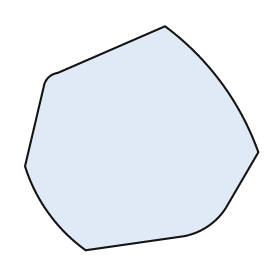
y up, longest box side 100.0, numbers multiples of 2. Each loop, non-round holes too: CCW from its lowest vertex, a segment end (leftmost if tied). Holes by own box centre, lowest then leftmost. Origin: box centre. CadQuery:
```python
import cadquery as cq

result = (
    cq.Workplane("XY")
    .moveTo(-24.0, -48.0)
    .lineTo(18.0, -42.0)
    .threePointArc((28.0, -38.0), (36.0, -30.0))
    .lineTo(50.0, -6.0)
    .threePointArc((34.0, 24.0), (10.0, 48.0))
    .lineTo(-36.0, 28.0)
    .threePointArc((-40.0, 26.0), (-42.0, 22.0))
    .lineTo(-50.0, -12.0)
    .threePointArc((-40.0, -32.0), (-24.0, -48.0))
    .close()
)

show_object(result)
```